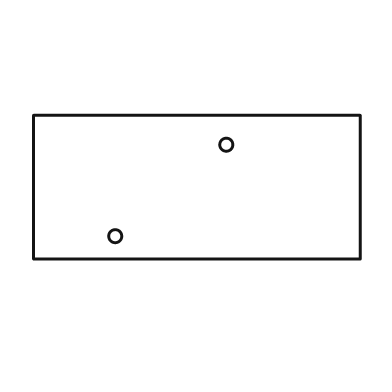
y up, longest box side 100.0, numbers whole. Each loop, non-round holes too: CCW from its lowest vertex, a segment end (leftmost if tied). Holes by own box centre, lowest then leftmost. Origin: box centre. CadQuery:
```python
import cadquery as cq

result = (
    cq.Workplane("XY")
    .moveTo(-50.0, -22.0)
    .lineTo(50.0, -22.0)
    .lineTo(50.0, 22.0)
    .lineTo(-50.0, 22.0)
    .close()
    .moveTo(-25.0, -15.0)
    .circle(2.0)
    .moveTo(9.0, 13.0)
    .circle(2.0)
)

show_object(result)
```